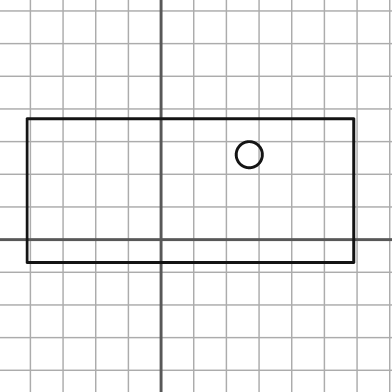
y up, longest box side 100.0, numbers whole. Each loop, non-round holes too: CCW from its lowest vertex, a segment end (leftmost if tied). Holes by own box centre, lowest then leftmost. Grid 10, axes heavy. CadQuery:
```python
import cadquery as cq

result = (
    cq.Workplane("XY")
    .moveTo(-41.0, -7.0)
    .lineTo(59.0, -7.0)
    .lineTo(59.0, 37.0)
    .lineTo(-41.0, 37.0)
    .close()
    .moveTo(27.0, 26.0)
    .circle(4.0)
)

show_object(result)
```